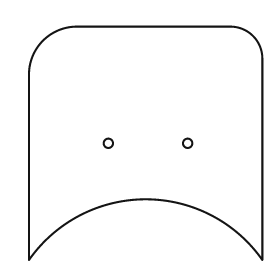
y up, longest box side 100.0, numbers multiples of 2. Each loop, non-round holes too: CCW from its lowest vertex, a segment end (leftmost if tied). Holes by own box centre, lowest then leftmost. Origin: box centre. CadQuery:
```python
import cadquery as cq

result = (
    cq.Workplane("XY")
    .moveTo(-50.0, -50.0)
    .threePointArc((0.0, -24.0), (50.0, -50.0))
    .lineTo(50.0, 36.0)
    .threePointArc((46.0, 46.0), (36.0, 50.0))
    .lineTo(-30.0, 50.0)
    .threePointArc((-44.0, 44.0), (-50.0, 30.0))
    .close()
    .moveTo(-16.0, 0.0)
    .circle(2.0)
    .moveTo(18.0, 0.0)
    .circle(2.0)
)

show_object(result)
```